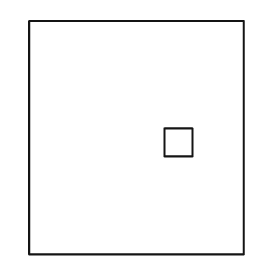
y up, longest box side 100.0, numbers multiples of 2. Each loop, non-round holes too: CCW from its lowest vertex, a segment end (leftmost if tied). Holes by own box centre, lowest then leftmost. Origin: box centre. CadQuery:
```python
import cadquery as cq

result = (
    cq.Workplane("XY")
    .moveTo(-46.0, -50.0)
    .lineTo(46.0, -50.0)
    .lineTo(46.0, 50.0)
    .lineTo(-46.0, 50.0)
    .close()
    .moveTo(12.0, -8.0)
    .lineTo(24.0, -8.0)
    .lineTo(24.0, 4.0)
    .lineTo(12.0, 4.0)
    .close()
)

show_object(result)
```